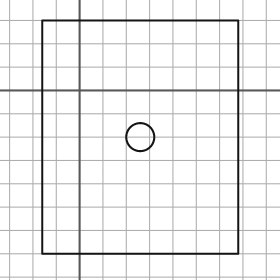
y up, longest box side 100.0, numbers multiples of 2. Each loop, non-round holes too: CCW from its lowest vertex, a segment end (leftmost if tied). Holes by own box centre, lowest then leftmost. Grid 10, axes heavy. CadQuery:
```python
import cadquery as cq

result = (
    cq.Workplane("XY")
    .moveTo(-16.0, -70.0)
    .lineTo(68.0, -70.0)
    .lineTo(68.0, 30.0)
    .lineTo(-16.0, 30.0)
    .close()
    .moveTo(26.0, -20.0)
    .circle(6.0)
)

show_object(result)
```